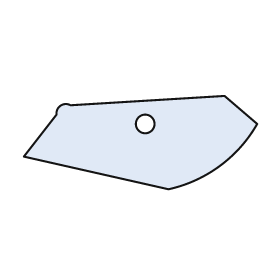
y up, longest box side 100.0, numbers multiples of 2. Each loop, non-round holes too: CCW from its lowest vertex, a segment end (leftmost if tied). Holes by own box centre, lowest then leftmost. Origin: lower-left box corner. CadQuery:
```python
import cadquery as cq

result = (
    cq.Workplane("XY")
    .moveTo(62.0, 0.0)
    .threePointArc((84.0, 10.0), (100.0, 28.0))
    .lineTo(86.0, 40.0)
    .lineTo(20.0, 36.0)
    .threePointArc((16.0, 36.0), (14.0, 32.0))
    .lineTo(0.0, 14.0)
    .close()
    .moveTo(52.0, 28.0)
    .circle(4.0)
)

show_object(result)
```